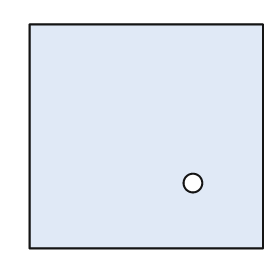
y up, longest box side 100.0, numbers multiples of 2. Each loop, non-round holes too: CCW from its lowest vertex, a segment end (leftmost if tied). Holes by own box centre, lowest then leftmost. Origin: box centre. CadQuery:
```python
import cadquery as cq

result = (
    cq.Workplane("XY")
    .moveTo(-50.0, -48.0)
    .lineTo(50.0, -48.0)
    .lineTo(50.0, 48.0)
    .lineTo(-50.0, 48.0)
    .close()
    .moveTo(20.0, -20.0)
    .circle(4.0)
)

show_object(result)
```